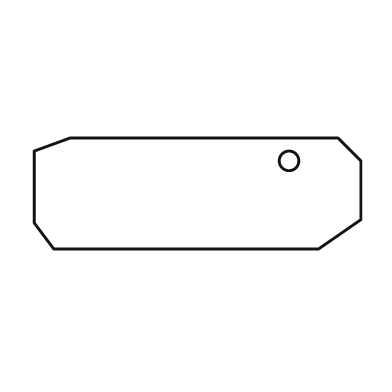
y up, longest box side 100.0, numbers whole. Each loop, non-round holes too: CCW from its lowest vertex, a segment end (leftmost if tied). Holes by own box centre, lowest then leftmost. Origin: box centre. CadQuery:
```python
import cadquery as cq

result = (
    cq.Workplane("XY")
    .moveTo(-44.0, -17.0)
    .lineTo(37.0, -17.0)
    .lineTo(50.0, -8.0)
    .lineTo(50.0, 10.0)
    .lineTo(43.0, 17.0)
    .lineTo(-39.0, 17.0)
    .lineTo(-50.0, 13.0)
    .lineTo(-50.0, -9.0)
    .close()
    .moveTo(28.0, 10.0)
    .circle(3.0)
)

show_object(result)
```